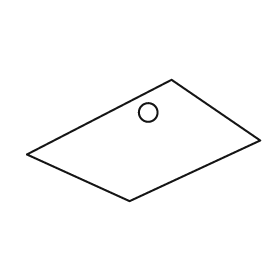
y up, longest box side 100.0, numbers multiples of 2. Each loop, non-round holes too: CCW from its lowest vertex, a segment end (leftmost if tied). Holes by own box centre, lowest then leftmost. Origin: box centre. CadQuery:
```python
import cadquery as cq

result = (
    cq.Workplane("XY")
    .moveTo(-6.0, -26.0)
    .lineTo(50.0, 0.0)
    .lineTo(12.0, 26.0)
    .lineTo(-50.0, -6.0)
    .close()
    .moveTo(2.0, 12.0)
    .circle(4.0)
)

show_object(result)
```